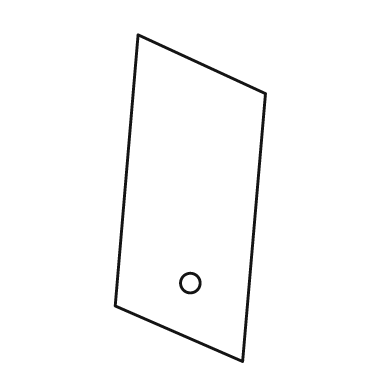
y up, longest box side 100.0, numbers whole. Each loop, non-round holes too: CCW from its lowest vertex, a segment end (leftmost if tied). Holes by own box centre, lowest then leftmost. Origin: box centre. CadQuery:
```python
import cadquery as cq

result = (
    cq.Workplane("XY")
    .moveTo(16.0, -50.0)
    .lineTo(23.0, 32.0)
    .lineTo(-16.0, 50.0)
    .lineTo(-23.0, -33.0)
    .close()
    .moveTo(0.0, -26.0)
    .circle(3.0)
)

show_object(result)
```